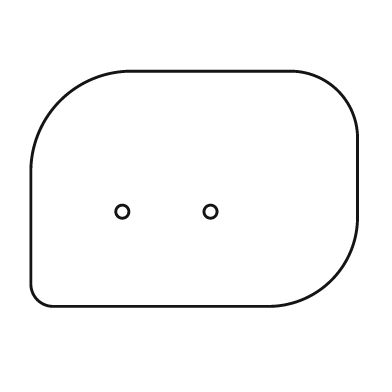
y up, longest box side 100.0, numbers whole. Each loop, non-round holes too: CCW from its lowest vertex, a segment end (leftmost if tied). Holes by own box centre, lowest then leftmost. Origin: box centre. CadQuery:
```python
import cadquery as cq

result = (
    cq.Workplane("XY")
    .moveTo(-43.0, -36.0)
    .lineTo(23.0, -36.0)
    .threePointArc((42.0, -28.0), (50.0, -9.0))
    .lineTo(50.0, 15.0)
    .threePointArc((44.0, 30.0), (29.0, 36.0))
    .lineTo(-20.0, 36.0)
    .threePointArc((-41.0, 27.0), (-50.0, 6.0))
    .lineTo(-50.0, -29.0)
    .threePointArc((-48.0, -34.0), (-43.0, -36.0))
    .close()
    .moveTo(-22.0, -7.0)
    .circle(2.0)
    .moveTo(5.0, -7.0)
    .circle(2.0)
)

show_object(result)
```